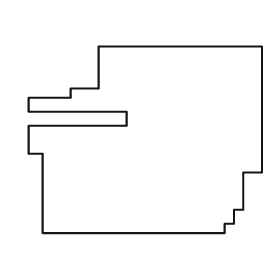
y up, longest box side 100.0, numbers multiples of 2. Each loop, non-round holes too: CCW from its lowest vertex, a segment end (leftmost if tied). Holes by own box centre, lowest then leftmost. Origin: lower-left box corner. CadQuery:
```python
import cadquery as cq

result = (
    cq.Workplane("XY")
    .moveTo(6.0, 0.0)
    .lineTo(84.0, 0.0)
    .lineTo(84.0, 4.0)
    .lineTo(88.0, 4.0)
    .lineTo(88.0, 10.0)
    .lineTo(92.0, 10.0)
    .lineTo(92.0, 26.0)
    .lineTo(100.0, 26.0)
    .lineTo(100.0, 80.0)
    .lineTo(30.0, 80.0)
    .lineTo(30.0, 62.0)
    .lineTo(18.0, 62.0)
    .lineTo(18.0, 58.0)
    .lineTo(0.0, 58.0)
    .lineTo(0.0, 52.0)
    .lineTo(42.0, 52.0)
    .lineTo(42.0, 46.0)
    .lineTo(0.0, 46.0)
    .lineTo(0.0, 34.0)
    .lineTo(6.0, 34.0)
    .close()
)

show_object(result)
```